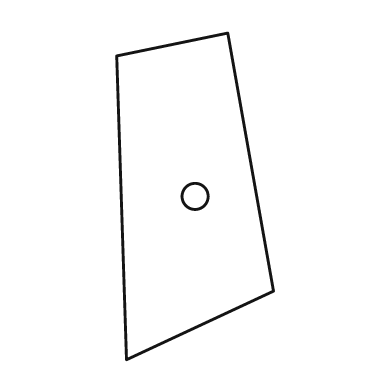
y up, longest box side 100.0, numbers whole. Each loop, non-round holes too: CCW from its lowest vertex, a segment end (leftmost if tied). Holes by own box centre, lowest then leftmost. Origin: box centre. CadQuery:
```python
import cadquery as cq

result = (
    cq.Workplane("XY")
    .moveTo(-21.0, -50.0)
    .lineTo(24.0, -29.0)
    .lineTo(10.0, 50.0)
    .lineTo(-24.0, 43.0)
    .close()
    .moveTo(0.0, 0.0)
    .circle(4.0)
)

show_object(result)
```